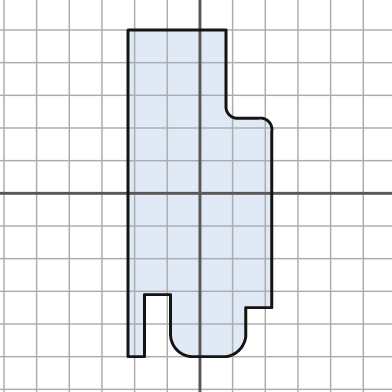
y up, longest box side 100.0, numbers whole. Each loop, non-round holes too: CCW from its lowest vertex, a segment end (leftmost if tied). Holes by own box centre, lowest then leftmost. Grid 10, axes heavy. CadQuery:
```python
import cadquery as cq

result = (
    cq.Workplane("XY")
    .moveTo(-22.0, -50.0)
    .lineTo(-17.0, -50.0)
    .lineTo(-17.0, -31.0)
    .lineTo(-9.0, -31.0)
    .lineTo(-9.0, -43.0)
    .threePointArc((-7.0, -48.0), (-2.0, -50.0))
    .lineTo(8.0, -50.0)
    .threePointArc((12.0, -48.0), (14.0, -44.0))
    .lineTo(14.0, -35.0)
    .lineTo(22.0, -35.0)
    .lineTo(22.0, 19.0)
    .threePointArc((21.0, 22.0), (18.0, 23.0))
    .lineTo(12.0, 23.0)
    .threePointArc((9.0, 24.0), (8.0, 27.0))
    .lineTo(8.0, 50.0)
    .lineTo(-22.0, 50.0)
    .close()
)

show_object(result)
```